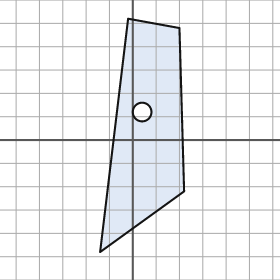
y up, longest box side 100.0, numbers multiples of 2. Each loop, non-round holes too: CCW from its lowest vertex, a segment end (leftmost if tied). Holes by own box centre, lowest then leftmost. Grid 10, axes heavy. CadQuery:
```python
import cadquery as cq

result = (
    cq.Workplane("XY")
    .moveTo(-14.0, -48.0)
    .lineTo(22.0, -22.0)
    .lineTo(20.0, 48.0)
    .lineTo(-2.0, 52.0)
    .close()
    .moveTo(4.0, 12.0)
    .circle(4.0)
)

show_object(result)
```